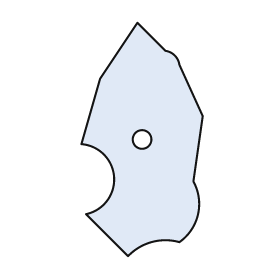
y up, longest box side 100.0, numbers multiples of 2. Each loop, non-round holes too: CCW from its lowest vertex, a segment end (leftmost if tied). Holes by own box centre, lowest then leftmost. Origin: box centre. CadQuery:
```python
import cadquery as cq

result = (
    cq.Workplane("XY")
    .moveTo(-6.0, -50.0)
    .threePointArc((4.0, -44.0), (16.0, -44.0))
    .threePointArc((24.0, -32.0), (22.0, -18.0))
    .lineTo(26.0, 10.0)
    .lineTo(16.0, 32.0)
    .threePointArc((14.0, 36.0), (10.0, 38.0))
    .lineTo(-2.0, 50.0)
    .lineTo(-18.0, 26.0)
    .lineTo(-26.0, -2.0)
    .threePointArc((-12.0, -16.0), (-24.0, -32.0))
    .close()
    .moveTo(0.0, 0.0)
    .circle(4.0)
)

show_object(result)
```